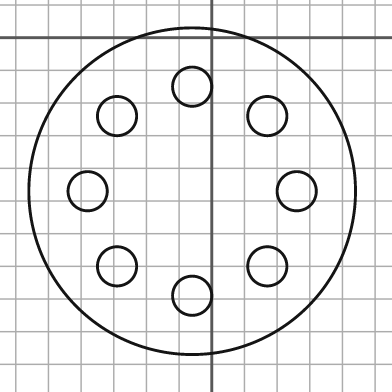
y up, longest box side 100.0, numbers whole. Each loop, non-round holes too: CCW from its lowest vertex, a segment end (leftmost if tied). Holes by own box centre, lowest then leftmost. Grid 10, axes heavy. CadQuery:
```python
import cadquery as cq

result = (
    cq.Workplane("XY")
    .moveTo(-6.0, -47.0)
    .circle(50.0)
    .moveTo(-6.0, -79.0)
    .circle(6.0)
    .moveTo(-29.0, -70.0)
    .circle(6.0)
    .moveTo(17.0, -70.0)
    .circle(6.0)
    .moveTo(-38.0, -47.0)
    .circle(6.0)
    .moveTo(26.0, -47.0)
    .circle(6.0)
    .moveTo(-29.0, -24.0)
    .circle(6.0)
    .moveTo(17.0, -24.0)
    .circle(6.0)
    .moveTo(-6.0, -15.0)
    .circle(6.0)
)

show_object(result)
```